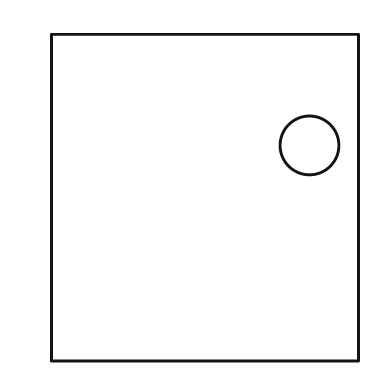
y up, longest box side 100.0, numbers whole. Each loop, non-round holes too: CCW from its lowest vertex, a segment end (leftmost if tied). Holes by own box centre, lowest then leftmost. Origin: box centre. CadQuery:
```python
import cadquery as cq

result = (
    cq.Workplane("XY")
    .moveTo(-47.0, -50.0)
    .lineTo(47.0, -50.0)
    .lineTo(47.0, 50.0)
    .lineTo(-47.0, 50.0)
    .close()
    .moveTo(32.0, 16.0)
    .circle(9.0)
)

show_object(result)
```